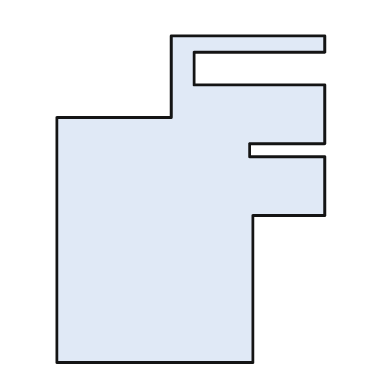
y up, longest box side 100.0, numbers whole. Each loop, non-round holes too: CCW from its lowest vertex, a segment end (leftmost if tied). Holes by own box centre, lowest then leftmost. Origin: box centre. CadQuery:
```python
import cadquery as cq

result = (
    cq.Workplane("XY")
    .moveTo(-41.0, -50.0)
    .lineTo(19.0, -50.0)
    .lineTo(19.0, -5.0)
    .lineTo(41.0, -5.0)
    .lineTo(41.0, 13.0)
    .lineTo(18.0, 13.0)
    .lineTo(18.0, 17.0)
    .lineTo(41.0, 17.0)
    .lineTo(41.0, 35.0)
    .lineTo(1.0, 35.0)
    .lineTo(1.0, 45.0)
    .lineTo(41.0, 45.0)
    .lineTo(41.0, 50.0)
    .lineTo(-6.0, 50.0)
    .lineTo(-6.0, 25.0)
    .lineTo(-41.0, 25.0)
    .close()
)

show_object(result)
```